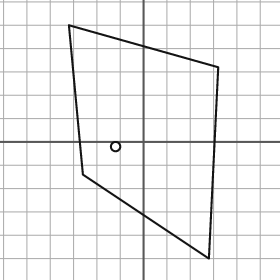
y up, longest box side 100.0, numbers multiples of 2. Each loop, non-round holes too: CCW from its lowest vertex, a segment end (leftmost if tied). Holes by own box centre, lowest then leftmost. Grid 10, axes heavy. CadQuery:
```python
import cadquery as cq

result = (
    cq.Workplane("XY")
    .moveTo(28.0, -50.0)
    .lineTo(32.0, 32.0)
    .lineTo(-32.0, 50.0)
    .lineTo(-26.0, -14.0)
    .close()
    .moveTo(-12.0, -2.0)
    .circle(2.0)
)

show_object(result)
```